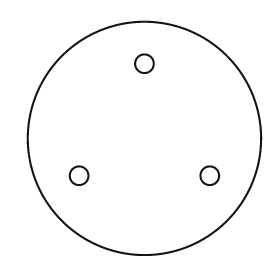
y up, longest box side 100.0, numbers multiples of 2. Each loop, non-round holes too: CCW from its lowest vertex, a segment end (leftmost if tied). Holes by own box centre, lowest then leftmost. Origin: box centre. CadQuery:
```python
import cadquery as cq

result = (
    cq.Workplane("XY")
    .moveTo(0.0, 0.0)
    .circle(50.0)
    .moveTo(-28.0, -16.0)
    .circle(4.0)
    .moveTo(28.0, -16.0)
    .circle(4.0)
    .moveTo(0.0, 32.0)
    .circle(4.0)
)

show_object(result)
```